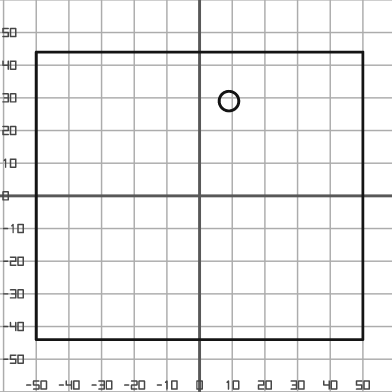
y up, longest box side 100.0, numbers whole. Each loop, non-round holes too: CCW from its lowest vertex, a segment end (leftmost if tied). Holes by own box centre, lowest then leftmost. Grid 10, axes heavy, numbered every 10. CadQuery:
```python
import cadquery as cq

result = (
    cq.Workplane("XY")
    .moveTo(-50.0, -44.0)
    .lineTo(50.0, -44.0)
    .lineTo(50.0, 44.0)
    .lineTo(-50.0, 44.0)
    .close()
    .moveTo(9.0, 29.0)
    .circle(3.0)
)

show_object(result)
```